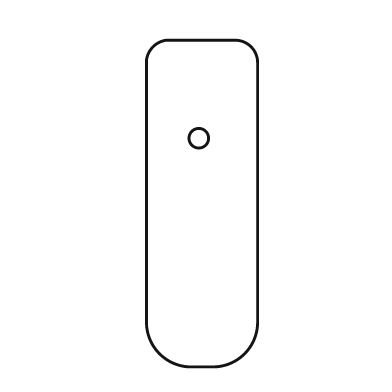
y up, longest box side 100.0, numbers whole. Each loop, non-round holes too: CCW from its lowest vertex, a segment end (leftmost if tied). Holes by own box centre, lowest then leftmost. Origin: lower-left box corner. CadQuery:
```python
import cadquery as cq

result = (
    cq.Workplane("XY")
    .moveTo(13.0, 0.0)
    .lineTo(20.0, 0.0)
    .threePointArc((30.0, 4.0), (34.0, 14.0))
    .lineTo(34.0, 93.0)
    .threePointArc((32.0, 98.0), (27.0, 100.0))
    .lineTo(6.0, 100.0)
    .threePointArc((2.0, 98.0), (0.0, 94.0))
    .lineTo(0.0, 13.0)
    .threePointArc((4.0, 4.0), (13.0, 0.0))
    .close()
    .moveTo(16.0, 70.0)
    .circle(3.0)
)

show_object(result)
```